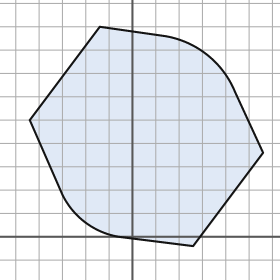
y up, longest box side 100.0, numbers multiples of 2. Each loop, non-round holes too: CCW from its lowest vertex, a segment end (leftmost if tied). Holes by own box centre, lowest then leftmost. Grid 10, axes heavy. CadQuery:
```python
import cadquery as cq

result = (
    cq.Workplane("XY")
    .moveTo(26.0, -4.0)
    .lineTo(56.0, 36.0)
    .lineTo(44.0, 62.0)
    .threePointArc((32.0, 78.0), (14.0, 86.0))
    .lineTo(-14.0, 90.0)
    .lineTo(-44.0, 50.0)
    .lineTo(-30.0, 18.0)
    .threePointArc((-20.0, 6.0), (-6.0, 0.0))
    .close()
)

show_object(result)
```